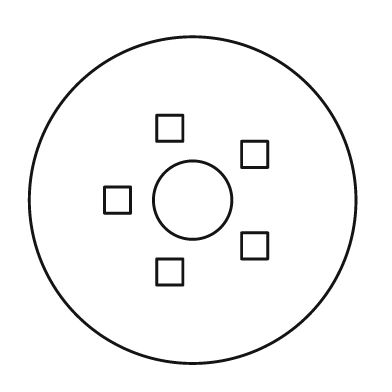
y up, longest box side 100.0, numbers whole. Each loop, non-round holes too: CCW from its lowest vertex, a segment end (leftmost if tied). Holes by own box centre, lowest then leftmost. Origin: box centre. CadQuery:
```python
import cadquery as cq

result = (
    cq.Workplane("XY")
    .moveTo(0.0, 0.0)
    .circle(50.0)
    .moveTo(-11.0, -26.0)
    .lineTo(-3.0, -26.0)
    .lineTo(-3.0, -18.0)
    .lineTo(-11.0, -18.0)
    .close()
    .moveTo(15.0, -18.0)
    .lineTo(23.0, -18.0)
    .lineTo(23.0, -10.0)
    .lineTo(15.0, -10.0)
    .close()
    .moveTo(-27.0, -4.0)
    .lineTo(-19.0, -4.0)
    .lineTo(-19.0, 4.0)
    .lineTo(-27.0, 4.0)
    .close()
    .moveTo(0.0, 0.0)
    .circle(12.0)
    .moveTo(15.0, 10.0)
    .lineTo(23.0, 10.0)
    .lineTo(23.0, 18.0)
    .lineTo(15.0, 18.0)
    .close()
    .moveTo(-11.0, 18.0)
    .lineTo(-3.0, 18.0)
    .lineTo(-3.0, 26.0)
    .lineTo(-11.0, 26.0)
    .close()
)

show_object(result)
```